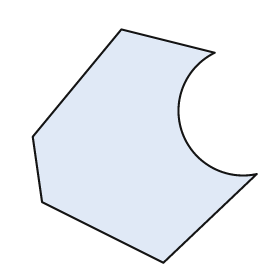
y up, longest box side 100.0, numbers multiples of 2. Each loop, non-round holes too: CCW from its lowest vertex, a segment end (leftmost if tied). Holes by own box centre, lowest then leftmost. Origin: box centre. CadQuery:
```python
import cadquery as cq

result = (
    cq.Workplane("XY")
    .moveTo(8.0, -50.0)
    .lineTo(48.0, -12.0)
    .threePointArc((16.0, 6.0), (30.0, 40.0))
    .lineTo(-10.0, 50.0)
    .lineTo(-48.0, 4.0)
    .lineTo(-44.0, -24.0)
    .close()
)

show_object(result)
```